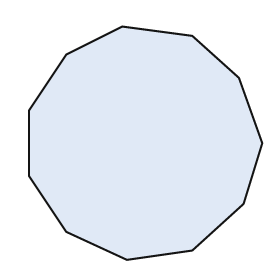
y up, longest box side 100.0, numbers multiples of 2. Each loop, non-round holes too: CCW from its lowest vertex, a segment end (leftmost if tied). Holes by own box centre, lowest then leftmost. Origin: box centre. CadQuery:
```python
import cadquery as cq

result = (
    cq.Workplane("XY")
    .moveTo(-8.0, -50.0)
    .lineTo(20.0, -46.0)
    .lineTo(42.0, -26.0)
    .lineTo(50.0, 0.0)
    .lineTo(40.0, 28.0)
    .lineTo(20.0, 46.0)
    .lineTo(-10.0, 50.0)
    .lineTo(-34.0, 38.0)
    .lineTo(-50.0, 14.0)
    .lineTo(-50.0, -14.0)
    .lineTo(-34.0, -38.0)
    .close()
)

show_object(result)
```